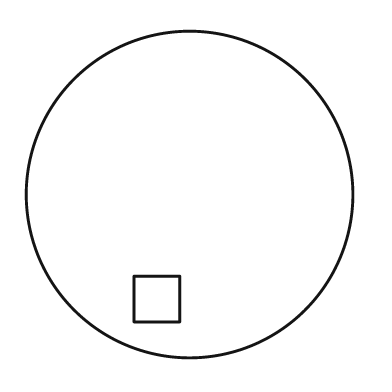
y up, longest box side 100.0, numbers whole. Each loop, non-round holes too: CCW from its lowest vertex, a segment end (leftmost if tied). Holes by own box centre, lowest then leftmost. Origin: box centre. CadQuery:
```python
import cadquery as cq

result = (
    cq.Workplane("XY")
    .moveTo(0.0, 0.0)
    .circle(50.0)
    .moveTo(-17.0, -39.0)
    .lineTo(-3.0, -39.0)
    .lineTo(-3.0, -25.0)
    .lineTo(-17.0, -25.0)
    .close()
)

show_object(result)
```